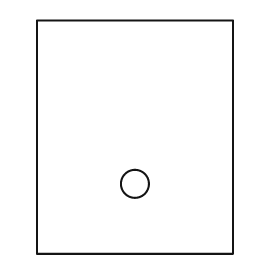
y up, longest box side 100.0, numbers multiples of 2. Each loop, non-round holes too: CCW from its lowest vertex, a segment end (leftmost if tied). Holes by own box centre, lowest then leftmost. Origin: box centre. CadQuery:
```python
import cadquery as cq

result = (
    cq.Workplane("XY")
    .moveTo(-42.0, -50.0)
    .lineTo(42.0, -50.0)
    .lineTo(42.0, 50.0)
    .lineTo(-42.0, 50.0)
    .close()
    .moveTo(0.0, -20.0)
    .circle(6.0)
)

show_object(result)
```